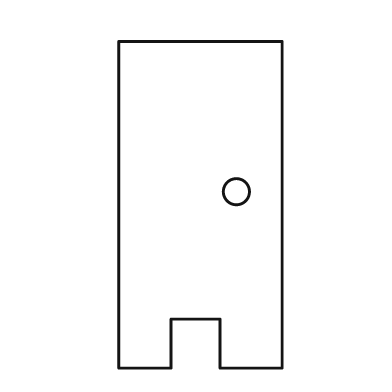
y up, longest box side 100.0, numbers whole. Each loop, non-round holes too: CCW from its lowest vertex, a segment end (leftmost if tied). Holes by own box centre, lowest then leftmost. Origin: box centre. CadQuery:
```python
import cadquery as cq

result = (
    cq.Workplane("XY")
    .moveTo(-25.0, -50.0)
    .lineTo(-9.0, -50.0)
    .lineTo(-9.0, -35.0)
    .lineTo(6.0, -35.0)
    .lineTo(6.0, -50.0)
    .lineTo(25.0, -50.0)
    .lineTo(25.0, 50.0)
    .lineTo(-25.0, 50.0)
    .close()
    .moveTo(11.0, 4.0)
    .circle(4.0)
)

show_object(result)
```